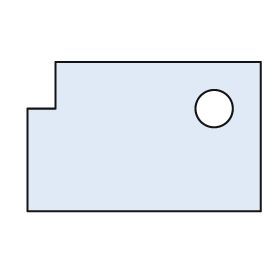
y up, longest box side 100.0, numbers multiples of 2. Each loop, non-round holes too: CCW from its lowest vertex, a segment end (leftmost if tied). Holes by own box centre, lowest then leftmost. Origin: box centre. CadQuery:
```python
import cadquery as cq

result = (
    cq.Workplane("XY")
    .moveTo(-50.0, -32.0)
    .lineTo(50.0, -32.0)
    .lineTo(50.0, 32.0)
    .lineTo(-38.0, 32.0)
    .lineTo(-38.0, 12.0)
    .lineTo(-50.0, 12.0)
    .close()
    .moveTo(30.0, 12.0)
    .circle(8.0)
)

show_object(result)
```